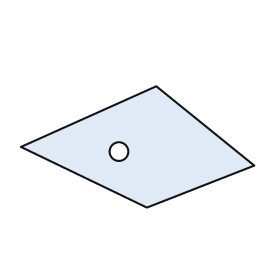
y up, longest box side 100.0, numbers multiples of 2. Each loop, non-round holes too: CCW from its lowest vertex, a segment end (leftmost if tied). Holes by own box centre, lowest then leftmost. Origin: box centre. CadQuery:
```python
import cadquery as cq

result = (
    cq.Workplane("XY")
    .moveTo(4.0, -26.0)
    .lineTo(50.0, -8.0)
    .lineTo(8.0, 26.0)
    .lineTo(-50.0, 0.0)
    .close()
    .moveTo(-8.0, -2.0)
    .circle(4.0)
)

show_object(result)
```